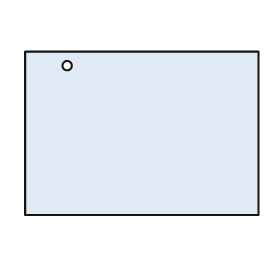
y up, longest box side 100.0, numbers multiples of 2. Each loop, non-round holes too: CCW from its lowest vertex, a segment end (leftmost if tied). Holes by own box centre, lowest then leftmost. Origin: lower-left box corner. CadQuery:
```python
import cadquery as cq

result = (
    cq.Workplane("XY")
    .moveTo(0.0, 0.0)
    .lineTo(100.0, 0.0)
    .lineTo(100.0, 70.0)
    .lineTo(0.0, 70.0)
    .close()
    .moveTo(18.0, 64.0)
    .circle(2.0)
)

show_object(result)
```